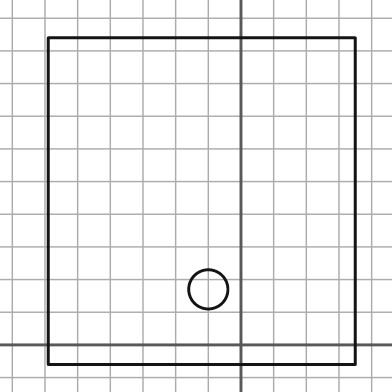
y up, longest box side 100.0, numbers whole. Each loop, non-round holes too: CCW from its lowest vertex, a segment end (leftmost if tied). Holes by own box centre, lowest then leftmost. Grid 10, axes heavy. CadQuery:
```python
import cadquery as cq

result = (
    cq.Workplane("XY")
    .moveTo(-59.0, -6.0)
    .lineTo(35.0, -6.0)
    .lineTo(35.0, 94.0)
    .lineTo(-59.0, 94.0)
    .close()
    .moveTo(-10.0, 17.0)
    .circle(6.0)
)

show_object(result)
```